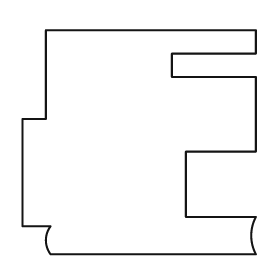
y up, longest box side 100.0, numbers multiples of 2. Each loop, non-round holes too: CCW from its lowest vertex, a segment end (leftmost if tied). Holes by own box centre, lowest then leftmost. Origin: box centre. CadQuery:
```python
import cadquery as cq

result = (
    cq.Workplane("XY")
    .moveTo(-38.0, -48.0)
    .lineTo(50.0, -48.0)
    .threePointArc((48.0, -40.0), (50.0, -32.0))
    .lineTo(20.0, -32.0)
    .lineTo(20.0, -4.0)
    .lineTo(50.0, -4.0)
    .lineTo(50.0, 28.0)
    .lineTo(14.0, 28.0)
    .lineTo(14.0, 38.0)
    .lineTo(50.0, 38.0)
    .lineTo(50.0, 48.0)
    .lineTo(-40.0, 48.0)
    .lineTo(-40.0, 10.0)
    .lineTo(-50.0, 10.0)
    .lineTo(-50.0, -36.0)
    .lineTo(-38.0, -36.0)
    .threePointArc((-40.0, -42.0), (-38.0, -48.0))
    .close()
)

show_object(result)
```